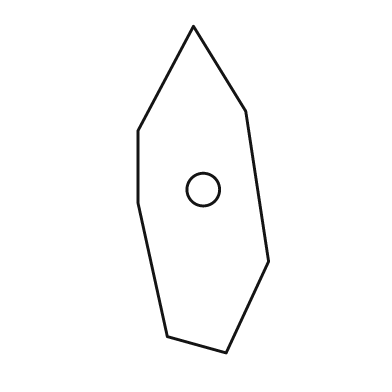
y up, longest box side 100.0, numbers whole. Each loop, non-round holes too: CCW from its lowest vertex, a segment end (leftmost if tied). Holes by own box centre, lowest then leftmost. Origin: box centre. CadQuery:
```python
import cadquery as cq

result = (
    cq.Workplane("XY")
    .moveTo(7.0, -50.0)
    .lineTo(20.0, -22.0)
    .lineTo(13.0, 24.0)
    .lineTo(-3.0, 50.0)
    .lineTo(-20.0, 18.0)
    .lineTo(-20.0, -4.0)
    .lineTo(-11.0, -45.0)
    .close()
    .moveTo(0.0, 0.0)
    .circle(5.0)
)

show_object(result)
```